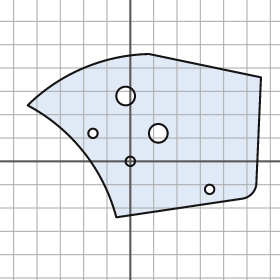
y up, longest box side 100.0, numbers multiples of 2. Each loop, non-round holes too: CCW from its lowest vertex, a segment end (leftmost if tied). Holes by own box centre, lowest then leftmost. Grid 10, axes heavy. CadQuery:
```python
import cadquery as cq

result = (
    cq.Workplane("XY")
    .moveTo(-6.0, -24.0)
    .lineTo(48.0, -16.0)
    .threePointArc((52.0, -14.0), (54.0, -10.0))
    .lineTo(56.0, 36.0)
    .lineTo(8.0, 46.0)
    .threePointArc((-20.0, 40.0), (-44.0, 24.0))
    .threePointArc((-20.0, 4.0), (-6.0, -24.0))
    .close()
    .moveTo(34.0, -12.0)
    .circle(2.0)
    .moveTo(0.0, 0.0)
    .circle(2.0)
    .moveTo(-16.0, 12.0)
    .circle(2.0)
    .moveTo(12.0, 12.0)
    .circle(4.0)
    .moveTo(-2.0, 28.0)
    .circle(4.0)
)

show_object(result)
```